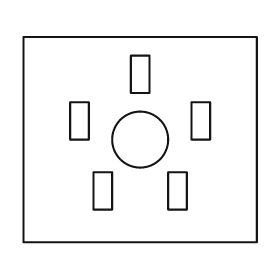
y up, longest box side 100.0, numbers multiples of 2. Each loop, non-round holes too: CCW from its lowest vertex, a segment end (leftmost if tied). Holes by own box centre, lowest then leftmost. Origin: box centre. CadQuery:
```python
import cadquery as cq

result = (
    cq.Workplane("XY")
    .moveTo(-50.0, -44.0)
    .lineTo(50.0, -44.0)
    .lineTo(50.0, 44.0)
    .lineTo(-50.0, 44.0)
    .close()
    .moveTo(-20.0, -30.0)
    .lineTo(-12.0, -30.0)
    .lineTo(-12.0, -14.0)
    .lineTo(-20.0, -14.0)
    .close()
    .moveTo(12.0, -30.0)
    .lineTo(20.0, -30.0)
    .lineTo(20.0, -14.0)
    .lineTo(12.0, -14.0)
    .close()
    .moveTo(0.0, 0.0)
    .circle(12.0)
    .moveTo(-30.0, 0.0)
    .lineTo(-22.0, 0.0)
    .lineTo(-22.0, 16.0)
    .lineTo(-30.0, 16.0)
    .close()
    .moveTo(22.0, 0.0)
    .lineTo(30.0, 0.0)
    .lineTo(30.0, 16.0)
    .lineTo(22.0, 16.0)
    .close()
    .moveTo(-4.0, 20.0)
    .lineTo(4.0, 20.0)
    .lineTo(4.0, 36.0)
    .lineTo(-4.0, 36.0)
    .close()
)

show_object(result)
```